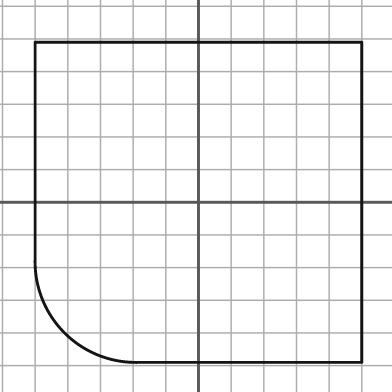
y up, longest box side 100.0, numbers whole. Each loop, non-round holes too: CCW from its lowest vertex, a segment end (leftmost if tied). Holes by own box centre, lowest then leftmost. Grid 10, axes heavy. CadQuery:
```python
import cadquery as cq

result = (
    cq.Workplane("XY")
    .moveTo(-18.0, -49.0)
    .lineTo(50.0, -49.0)
    .lineTo(50.0, 49.0)
    .lineTo(-50.0, 49.0)
    .lineTo(-50.0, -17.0)
    .threePointArc((-41.0, -40.0), (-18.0, -49.0))
    .close()
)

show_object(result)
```